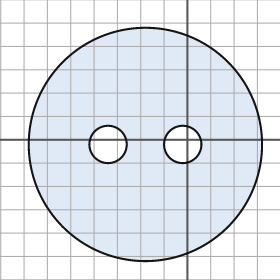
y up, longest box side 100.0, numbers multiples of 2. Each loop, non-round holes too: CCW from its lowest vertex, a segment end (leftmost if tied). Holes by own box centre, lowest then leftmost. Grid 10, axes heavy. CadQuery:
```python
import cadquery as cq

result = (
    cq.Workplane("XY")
    .moveTo(-18.0, -2.0)
    .circle(50.0)
    .moveTo(-34.0, -2.0)
    .circle(8.0)
    .moveTo(-2.0, -2.0)
    .circle(8.0)
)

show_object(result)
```